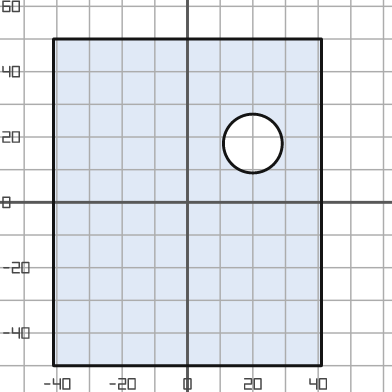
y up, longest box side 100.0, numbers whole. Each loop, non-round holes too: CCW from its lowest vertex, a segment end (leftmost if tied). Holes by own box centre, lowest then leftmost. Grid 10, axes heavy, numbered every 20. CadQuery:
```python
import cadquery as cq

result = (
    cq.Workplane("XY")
    .moveTo(-41.0, -50.0)
    .lineTo(41.0, -50.0)
    .lineTo(41.0, 50.0)
    .lineTo(-41.0, 50.0)
    .close()
    .moveTo(20.0, 18.0)
    .circle(9.0)
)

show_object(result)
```